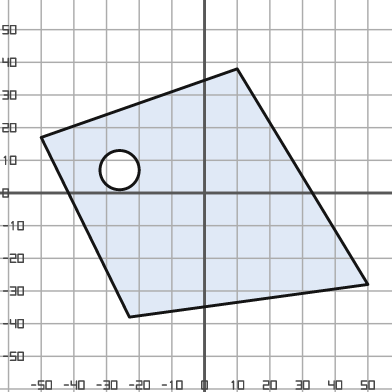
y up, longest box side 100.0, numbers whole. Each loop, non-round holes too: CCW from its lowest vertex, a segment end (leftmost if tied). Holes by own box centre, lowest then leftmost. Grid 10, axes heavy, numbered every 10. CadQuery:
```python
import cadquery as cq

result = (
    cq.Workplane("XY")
    .moveTo(-23.0, -38.0)
    .lineTo(50.0, -28.0)
    .lineTo(10.0, 38.0)
    .lineTo(-50.0, 17.0)
    .close()
    .moveTo(-26.0, 7.0)
    .circle(6.0)
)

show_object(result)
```